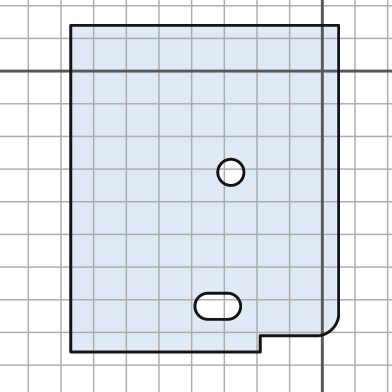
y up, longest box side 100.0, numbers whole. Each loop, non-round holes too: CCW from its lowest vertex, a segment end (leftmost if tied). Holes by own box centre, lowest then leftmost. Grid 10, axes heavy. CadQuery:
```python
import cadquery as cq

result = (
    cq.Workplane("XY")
    .moveTo(-77.0, -86.0)
    .lineTo(-19.0, -86.0)
    .lineTo(-19.0, -81.0)
    .lineTo(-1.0, -81.0)
    .threePointArc((3.0, -79.0), (5.0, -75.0))
    .lineTo(5.0, 14.0)
    .lineTo(-77.0, 14.0)
    .close()
    .moveTo(-35.0, -76.0)
    .lineTo(-29.0, -76.0)
    .threePointArc((-25.0, -72.0), (-29.0, -68.0))
    .lineTo(-35.0, -68.0)
    .threePointArc((-39.0, -72.0), (-35.0, -76.0))
    .close()
    .moveTo(-28.0, -31.0)
    .circle(4.0)
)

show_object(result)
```